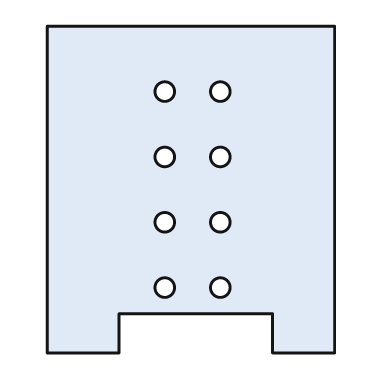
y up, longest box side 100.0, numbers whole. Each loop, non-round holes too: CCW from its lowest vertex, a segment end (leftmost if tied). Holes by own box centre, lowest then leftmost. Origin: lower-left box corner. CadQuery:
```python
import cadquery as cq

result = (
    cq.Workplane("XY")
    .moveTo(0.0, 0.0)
    .lineTo(22.0, 0.0)
    .lineTo(22.0, 12.0)
    .lineTo(69.0, 12.0)
    .lineTo(69.0, 0.0)
    .lineTo(88.0, 0.0)
    .lineTo(88.0, 100.0)
    .lineTo(0.0, 100.0)
    .close()
    .moveTo(36.0, 20.0)
    .circle(3.0)
    .moveTo(53.0, 20.0)
    .circle(3.0)
    .moveTo(36.0, 40.0)
    .circle(3.0)
    .moveTo(53.0, 40.0)
    .circle(3.0)
    .moveTo(36.0, 60.0)
    .circle(3.0)
    .moveTo(53.0, 60.0)
    .circle(3.0)
    .moveTo(36.0, 80.0)
    .circle(3.0)
    .moveTo(53.0, 80.0)
    .circle(3.0)
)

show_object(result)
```